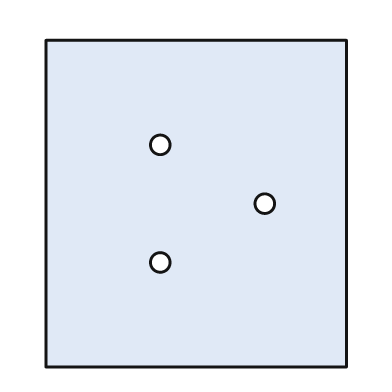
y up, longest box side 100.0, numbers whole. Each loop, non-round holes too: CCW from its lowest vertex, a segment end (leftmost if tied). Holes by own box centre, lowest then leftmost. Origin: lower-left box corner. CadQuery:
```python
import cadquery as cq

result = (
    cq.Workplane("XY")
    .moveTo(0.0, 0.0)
    .lineTo(92.0, 0.0)
    .lineTo(92.0, 100.0)
    .lineTo(0.0, 100.0)
    .close()
    .moveTo(35.0, 32.0)
    .circle(3.0)
    .moveTo(67.0, 50.0)
    .circle(3.0)
    .moveTo(35.0, 68.0)
    .circle(3.0)
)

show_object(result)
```